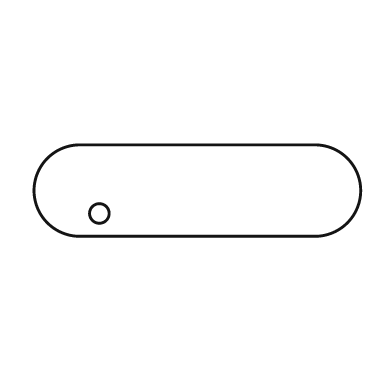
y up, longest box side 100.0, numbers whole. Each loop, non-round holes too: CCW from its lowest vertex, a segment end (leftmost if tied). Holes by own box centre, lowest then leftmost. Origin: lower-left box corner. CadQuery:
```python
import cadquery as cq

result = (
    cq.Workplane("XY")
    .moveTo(14.0, 0.0)
    .lineTo(86.0, 0.0)
    .threePointArc((100.0, 14.0), (86.0, 28.0))
    .lineTo(14.0, 28.0)
    .threePointArc((0.0, 14.0), (14.0, 0.0))
    .close()
    .moveTo(20.0, 7.0)
    .circle(3.0)
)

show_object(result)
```